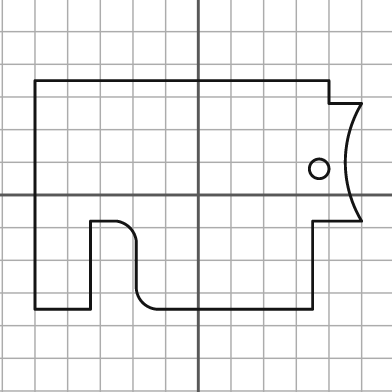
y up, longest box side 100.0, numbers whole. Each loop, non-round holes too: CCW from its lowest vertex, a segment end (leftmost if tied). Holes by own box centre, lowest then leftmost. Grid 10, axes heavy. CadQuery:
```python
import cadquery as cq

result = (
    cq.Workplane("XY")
    .moveTo(-50.0, -35.0)
    .lineTo(-33.0, -35.0)
    .lineTo(-33.0, -8.0)
    .lineTo(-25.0, -8.0)
    .threePointArc((-21.0, -10.0), (-19.0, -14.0))
    .lineTo(-19.0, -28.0)
    .threePointArc((-17.0, -33.0), (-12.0, -35.0))
    .lineTo(35.0, -35.0)
    .lineTo(35.0, -8.0)
    .lineTo(50.0, -8.0)
    .threePointArc((45.0, 10.0), (50.0, 28.0))
    .lineTo(40.0, 28.0)
    .lineTo(40.0, 35.0)
    .lineTo(-50.0, 35.0)
    .close()
    .moveTo(37.0, 8.0)
    .circle(3.0)
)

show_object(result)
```